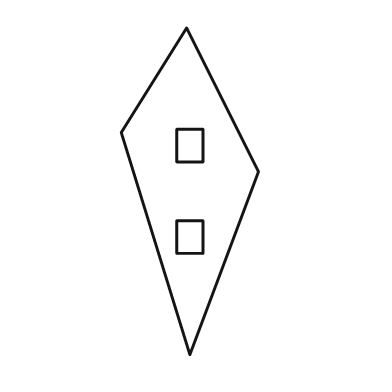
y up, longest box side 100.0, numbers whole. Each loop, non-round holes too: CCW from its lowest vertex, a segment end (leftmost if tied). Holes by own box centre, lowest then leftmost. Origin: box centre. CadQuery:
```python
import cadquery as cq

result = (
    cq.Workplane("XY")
    .moveTo(0.0, -50.0)
    .lineTo(21.0, 6.0)
    .lineTo(-1.0, 50.0)
    .lineTo(-21.0, 18.0)
    .close()
    .moveTo(-4.0, -19.0)
    .lineTo(4.0, -19.0)
    .lineTo(4.0, -9.0)
    .lineTo(-4.0, -9.0)
    .close()
    .moveTo(-4.0, 9.0)
    .lineTo(4.0, 9.0)
    .lineTo(4.0, 19.0)
    .lineTo(-4.0, 19.0)
    .close()
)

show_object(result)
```